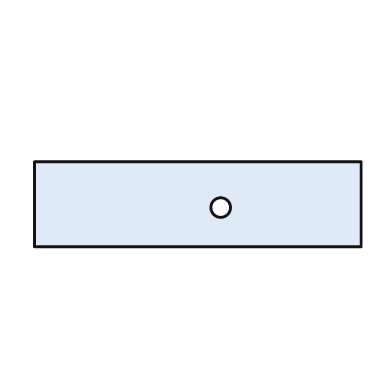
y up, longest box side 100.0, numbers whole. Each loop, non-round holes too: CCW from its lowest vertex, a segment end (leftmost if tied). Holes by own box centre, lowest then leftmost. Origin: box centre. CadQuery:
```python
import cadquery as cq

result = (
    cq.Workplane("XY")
    .moveTo(-50.0, -13.0)
    .lineTo(50.0, -13.0)
    .lineTo(50.0, 13.0)
    .lineTo(-50.0, 13.0)
    .close()
    .moveTo(7.0, -1.0)
    .circle(3.0)
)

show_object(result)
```